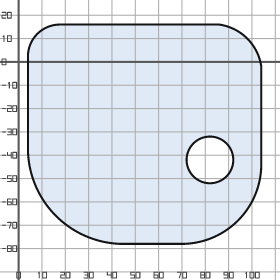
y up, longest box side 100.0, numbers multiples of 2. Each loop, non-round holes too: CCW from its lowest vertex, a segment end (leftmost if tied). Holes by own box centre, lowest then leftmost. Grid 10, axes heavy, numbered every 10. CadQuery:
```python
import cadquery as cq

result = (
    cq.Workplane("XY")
    .moveTo(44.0, -78.0)
    .lineTo(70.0, -78.0)
    .threePointArc((94.0, -68.0), (104.0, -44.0))
    .lineTo(104.0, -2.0)
    .threePointArc((98.0, 10.0), (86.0, 16.0))
    .lineTo(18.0, 16.0)
    .threePointArc((8.0, 12.0), (4.0, 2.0))
    .lineTo(4.0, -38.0)
    .threePointArc((16.0, -66.0), (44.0, -78.0))
    .close()
    .moveTo(82.0, -42.0)
    .circle(10.0)
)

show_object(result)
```